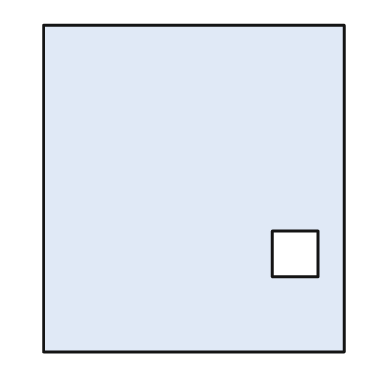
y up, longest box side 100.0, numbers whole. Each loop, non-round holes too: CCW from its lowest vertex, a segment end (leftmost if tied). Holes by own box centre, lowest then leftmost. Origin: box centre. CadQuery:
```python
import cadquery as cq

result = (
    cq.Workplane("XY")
    .moveTo(-46.0, -50.0)
    .lineTo(46.0, -50.0)
    .lineTo(46.0, 50.0)
    .lineTo(-46.0, 50.0)
    .close()
    .moveTo(24.0, -27.0)
    .lineTo(38.0, -27.0)
    .lineTo(38.0, -13.0)
    .lineTo(24.0, -13.0)
    .close()
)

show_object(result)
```